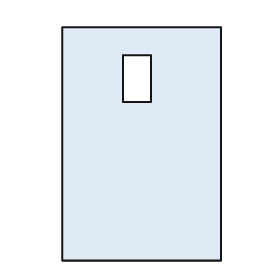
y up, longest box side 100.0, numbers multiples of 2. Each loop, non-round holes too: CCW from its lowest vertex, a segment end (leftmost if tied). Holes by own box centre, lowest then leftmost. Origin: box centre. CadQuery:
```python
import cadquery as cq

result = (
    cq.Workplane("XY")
    .moveTo(-34.0, -50.0)
    .lineTo(34.0, -50.0)
    .lineTo(34.0, 50.0)
    .lineTo(-34.0, 50.0)
    .close()
    .moveTo(-8.0, 18.0)
    .lineTo(4.0, 18.0)
    .lineTo(4.0, 38.0)
    .lineTo(-8.0, 38.0)
    .close()
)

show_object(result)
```